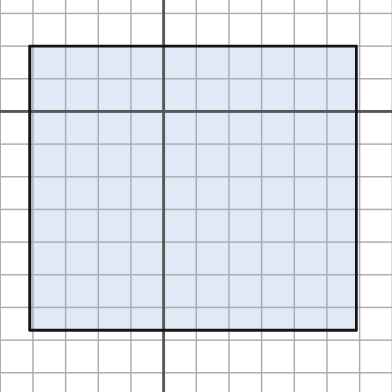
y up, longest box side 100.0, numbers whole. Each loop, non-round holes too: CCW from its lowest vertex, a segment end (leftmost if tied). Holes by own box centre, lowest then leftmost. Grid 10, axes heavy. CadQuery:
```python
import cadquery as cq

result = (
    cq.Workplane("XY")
    .moveTo(-41.0, -67.0)
    .lineTo(59.0, -67.0)
    .lineTo(59.0, 20.0)
    .lineTo(-41.0, 20.0)
    .close()
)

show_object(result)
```